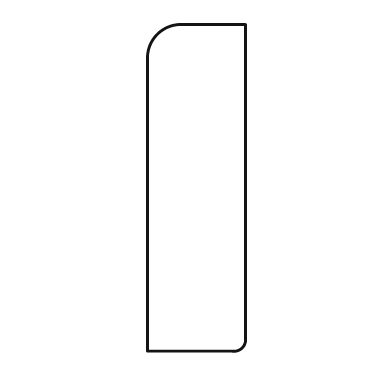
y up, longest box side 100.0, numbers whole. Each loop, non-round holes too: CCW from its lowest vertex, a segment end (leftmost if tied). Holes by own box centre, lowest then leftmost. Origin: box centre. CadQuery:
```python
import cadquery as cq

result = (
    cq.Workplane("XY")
    .moveTo(-15.0, -50.0)
    .lineTo(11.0, -50.0)
    .threePointArc((14.0, -49.0), (15.0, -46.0))
    .lineTo(15.0, 50.0)
    .lineTo(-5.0, 50.0)
    .threePointArc((-12.0, 47.0), (-15.0, 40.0))
    .close()
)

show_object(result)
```